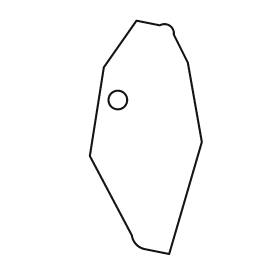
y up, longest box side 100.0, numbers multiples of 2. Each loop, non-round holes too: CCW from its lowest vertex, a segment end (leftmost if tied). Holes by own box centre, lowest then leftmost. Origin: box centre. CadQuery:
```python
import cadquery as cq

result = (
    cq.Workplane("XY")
    .moveTo(10.0, -50.0)
    .lineTo(24.0, -2.0)
    .lineTo(18.0, 32.0)
    .lineTo(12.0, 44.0)
    .threePointArc((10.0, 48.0), (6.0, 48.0))
    .lineTo(-4.0, 50.0)
    .lineTo(-18.0, 30.0)
    .lineTo(-24.0, -8.0)
    .lineTo(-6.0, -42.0)
    .threePointArc((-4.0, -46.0), (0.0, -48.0))
    .close()
    .moveTo(-12.0, 16.0)
    .circle(4.0)
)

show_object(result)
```